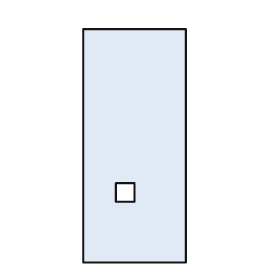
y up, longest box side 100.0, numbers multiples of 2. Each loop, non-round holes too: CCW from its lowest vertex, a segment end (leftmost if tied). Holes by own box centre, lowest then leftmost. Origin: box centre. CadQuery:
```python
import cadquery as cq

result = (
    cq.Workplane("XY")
    .moveTo(-22.0, -50.0)
    .lineTo(22.0, -50.0)
    .lineTo(22.0, 50.0)
    .lineTo(-22.0, 50.0)
    .close()
    .moveTo(-8.0, -24.0)
    .lineTo(0.0, -24.0)
    .lineTo(0.0, -16.0)
    .lineTo(-8.0, -16.0)
    .close()
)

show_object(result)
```